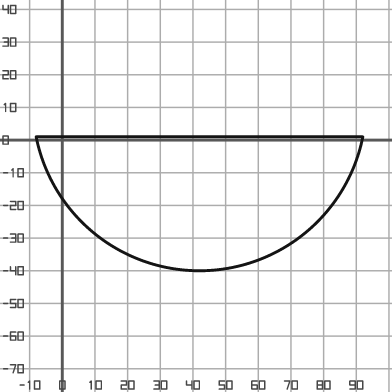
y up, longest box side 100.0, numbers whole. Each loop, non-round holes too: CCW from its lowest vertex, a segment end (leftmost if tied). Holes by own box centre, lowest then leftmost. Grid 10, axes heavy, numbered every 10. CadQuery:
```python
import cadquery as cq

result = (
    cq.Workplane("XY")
    .moveTo(-8.0, 1.0)
    .threePointArc((42.0, -40.0), (92.0, 1.0))
    .close()
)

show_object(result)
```